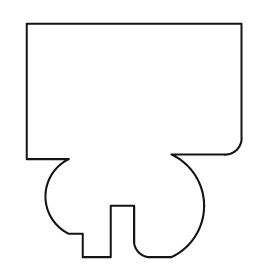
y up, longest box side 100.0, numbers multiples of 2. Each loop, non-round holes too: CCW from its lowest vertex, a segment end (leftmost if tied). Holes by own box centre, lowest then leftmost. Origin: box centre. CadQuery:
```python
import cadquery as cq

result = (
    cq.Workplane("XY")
    .moveTo(-22.0, -50.0)
    .lineTo(-10.0, -50.0)
    .lineTo(-10.0, -28.0)
    .lineTo(0.0, -28.0)
    .lineTo(0.0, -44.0)
    .threePointArc((2.0, -48.0), (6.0, -50.0))
    .lineTo(16.0, -50.0)
    .threePointArc((30.0, -28.0), (16.0, -6.0))
    .lineTo(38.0, -6.0)
    .threePointArc((44.0, -4.0), (46.0, 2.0))
    .lineTo(46.0, 50.0)
    .lineTo(-46.0, 50.0)
    .lineTo(-46.0, -8.0)
    .lineTo(-28.0, -8.0)
    .threePointArc((-38.0, -24.0), (-28.0, -40.0))
    .lineTo(-22.0, -40.0)
    .close()
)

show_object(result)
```